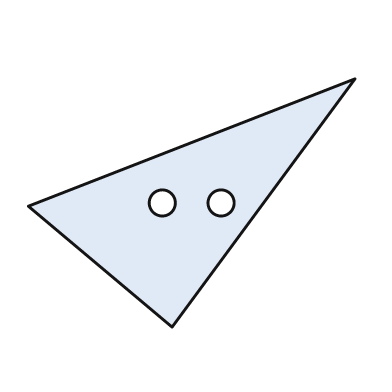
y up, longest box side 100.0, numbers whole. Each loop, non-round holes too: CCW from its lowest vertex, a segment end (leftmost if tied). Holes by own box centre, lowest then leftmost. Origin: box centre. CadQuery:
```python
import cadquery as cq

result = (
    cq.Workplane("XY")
    .moveTo(-6.0, -38.0)
    .lineTo(50.0, 38.0)
    .lineTo(-50.0, -1.0)
    .close()
    .moveTo(-9.0, 0.0)
    .circle(4.0)
    .moveTo(9.0, 0.0)
    .circle(4.0)
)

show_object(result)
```